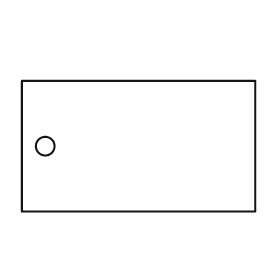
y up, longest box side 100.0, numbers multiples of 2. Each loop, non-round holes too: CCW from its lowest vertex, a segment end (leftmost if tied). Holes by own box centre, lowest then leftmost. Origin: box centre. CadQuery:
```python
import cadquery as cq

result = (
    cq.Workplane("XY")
    .moveTo(-50.0, -28.0)
    .lineTo(50.0, -28.0)
    .lineTo(50.0, 28.0)
    .lineTo(-50.0, 28.0)
    .close()
    .moveTo(-40.0, 0.0)
    .circle(4.0)
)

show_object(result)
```